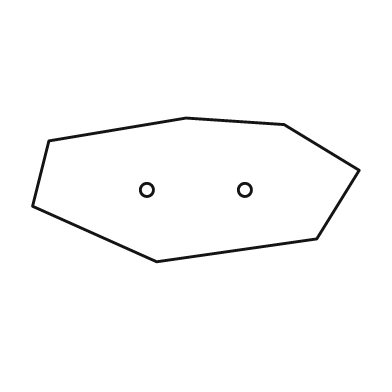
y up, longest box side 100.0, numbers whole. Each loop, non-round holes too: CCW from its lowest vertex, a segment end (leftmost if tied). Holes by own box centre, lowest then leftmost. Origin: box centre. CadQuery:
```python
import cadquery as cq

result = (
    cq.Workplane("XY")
    .moveTo(-12.0, -22.0)
    .lineTo(37.0, -15.0)
    .lineTo(50.0, 6.0)
    .lineTo(27.0, 20.0)
    .lineTo(-3.0, 22.0)
    .lineTo(-45.0, 15.0)
    .lineTo(-50.0, -5.0)
    .close()
    .moveTo(-15.0, 0.0)
    .circle(2.0)
    .moveTo(15.0, 0.0)
    .circle(2.0)
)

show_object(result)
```